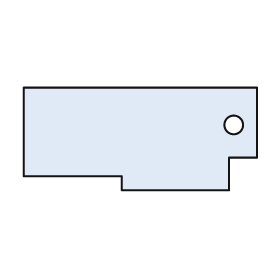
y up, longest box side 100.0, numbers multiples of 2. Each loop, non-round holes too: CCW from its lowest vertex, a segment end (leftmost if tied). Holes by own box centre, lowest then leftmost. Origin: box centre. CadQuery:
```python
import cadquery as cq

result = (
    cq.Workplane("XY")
    .moveTo(-8.0, -22.0)
    .lineTo(38.0, -22.0)
    .lineTo(38.0, -8.0)
    .lineTo(50.0, -8.0)
    .lineTo(50.0, 22.0)
    .lineTo(-50.0, 22.0)
    .lineTo(-50.0, -16.0)
    .lineTo(-8.0, -16.0)
    .close()
    .moveTo(40.0, 6.0)
    .circle(4.0)
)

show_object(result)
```